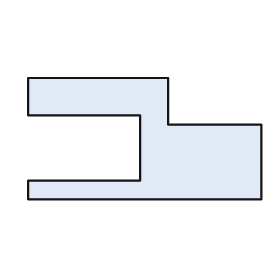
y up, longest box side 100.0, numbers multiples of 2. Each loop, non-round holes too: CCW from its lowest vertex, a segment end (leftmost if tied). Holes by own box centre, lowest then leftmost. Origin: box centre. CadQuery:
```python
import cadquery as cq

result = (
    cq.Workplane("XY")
    .moveTo(-50.0, -26.0)
    .lineTo(50.0, -26.0)
    .lineTo(50.0, 6.0)
    .lineTo(10.0, 6.0)
    .lineTo(10.0, 26.0)
    .lineTo(-50.0, 26.0)
    .lineTo(-50.0, 10.0)
    .lineTo(-2.0, 10.0)
    .lineTo(-2.0, -18.0)
    .lineTo(-50.0, -18.0)
    .close()
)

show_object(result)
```